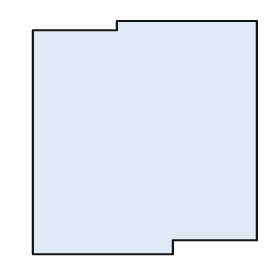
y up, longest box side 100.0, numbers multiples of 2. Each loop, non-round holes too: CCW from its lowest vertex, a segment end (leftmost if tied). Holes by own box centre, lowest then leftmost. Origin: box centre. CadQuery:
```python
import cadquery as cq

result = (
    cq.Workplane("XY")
    .moveTo(-48.0, -50.0)
    .lineTo(12.0, -50.0)
    .lineTo(12.0, -44.0)
    .lineTo(48.0, -44.0)
    .lineTo(48.0, 50.0)
    .lineTo(-12.0, 50.0)
    .lineTo(-12.0, 46.0)
    .lineTo(-48.0, 46.0)
    .close()
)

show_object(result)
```